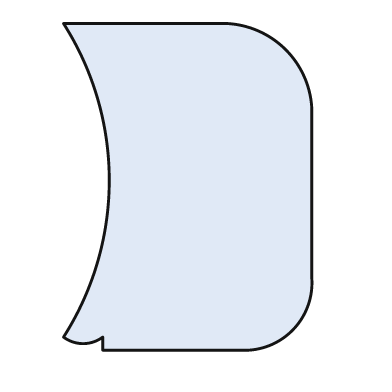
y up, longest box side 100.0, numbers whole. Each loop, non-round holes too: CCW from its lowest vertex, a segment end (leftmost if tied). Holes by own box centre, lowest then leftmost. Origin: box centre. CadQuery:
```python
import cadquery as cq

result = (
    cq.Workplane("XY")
    .moveTo(-26.0, -50.0)
    .lineTo(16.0, -50.0)
    .threePointArc((32.0, -44.0), (38.0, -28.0))
    .lineTo(38.0, 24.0)
    .threePointArc((30.0, 42.0), (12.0, 50.0))
    .lineTo(-38.0, 50.0)
    .threePointArc((-24.0, 2.0), (-38.0, -46.0))
    .threePointArc((-32.0, -48.0), (-26.0, -46.0))
    .close()
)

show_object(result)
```